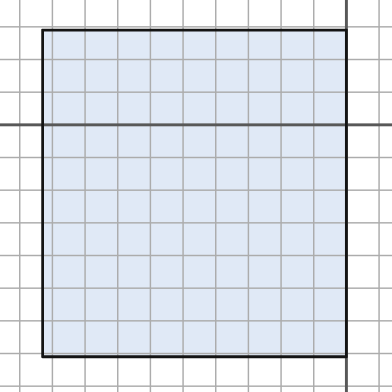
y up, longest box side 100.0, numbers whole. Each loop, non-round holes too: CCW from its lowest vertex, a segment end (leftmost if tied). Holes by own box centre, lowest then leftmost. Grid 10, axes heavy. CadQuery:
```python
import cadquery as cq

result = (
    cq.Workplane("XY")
    .moveTo(-93.0, -71.0)
    .lineTo(0.0, -71.0)
    .lineTo(0.0, 29.0)
    .lineTo(-93.0, 29.0)
    .close()
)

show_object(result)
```